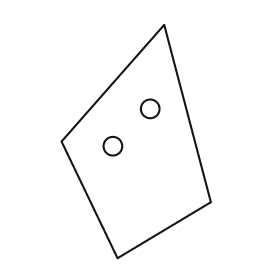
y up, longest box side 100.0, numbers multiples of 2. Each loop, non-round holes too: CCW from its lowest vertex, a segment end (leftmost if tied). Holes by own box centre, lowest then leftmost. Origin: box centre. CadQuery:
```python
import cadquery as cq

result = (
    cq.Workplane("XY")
    .moveTo(-8.0, -50.0)
    .lineTo(32.0, -26.0)
    .lineTo(12.0, 50.0)
    .lineTo(-32.0, 0.0)
    .close()
    .moveTo(-10.0, -2.0)
    .circle(4.0)
    .moveTo(6.0, 14.0)
    .circle(4.0)
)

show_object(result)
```